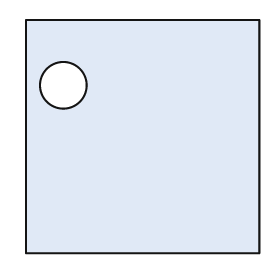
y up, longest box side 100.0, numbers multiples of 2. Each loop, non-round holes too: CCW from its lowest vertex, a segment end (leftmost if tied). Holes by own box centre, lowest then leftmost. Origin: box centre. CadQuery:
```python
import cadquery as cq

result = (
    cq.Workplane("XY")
    .moveTo(-50.0, -50.0)
    .lineTo(50.0, -50.0)
    .lineTo(50.0, 50.0)
    .lineTo(-50.0, 50.0)
    .close()
    .moveTo(-34.0, 22.0)
    .circle(10.0)
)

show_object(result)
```